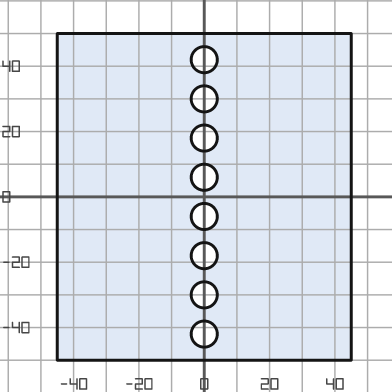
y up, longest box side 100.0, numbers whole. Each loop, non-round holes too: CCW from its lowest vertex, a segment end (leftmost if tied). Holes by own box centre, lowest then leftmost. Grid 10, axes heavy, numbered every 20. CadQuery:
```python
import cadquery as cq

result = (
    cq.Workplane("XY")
    .moveTo(-45.0, -50.0)
    .lineTo(45.0, -50.0)
    .lineTo(45.0, 50.0)
    .lineTo(-45.0, 50.0)
    .close()
    .moveTo(0.0, -42.0)
    .circle(4.0)
    .moveTo(0.0, -30.0)
    .circle(4.0)
    .moveTo(0.0, -18.0)
    .circle(4.0)
    .moveTo(0.0, -6.0)
    .circle(4.0)
    .moveTo(0.0, 6.0)
    .circle(4.0)
    .moveTo(0.0, 18.0)
    .circle(4.0)
    .moveTo(0.0, 30.0)
    .circle(4.0)
    .moveTo(0.0, 42.0)
    .circle(4.0)
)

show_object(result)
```